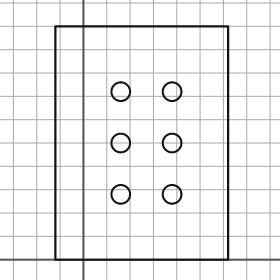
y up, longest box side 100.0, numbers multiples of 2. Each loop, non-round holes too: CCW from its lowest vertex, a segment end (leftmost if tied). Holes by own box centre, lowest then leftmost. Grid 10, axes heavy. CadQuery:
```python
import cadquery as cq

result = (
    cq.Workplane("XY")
    .moveTo(-12.0, 0.0)
    .lineTo(62.0, 0.0)
    .lineTo(62.0, 100.0)
    .lineTo(-12.0, 100.0)
    .close()
    .moveTo(16.0, 28.0)
    .circle(4.0)
    .moveTo(38.0, 28.0)
    .circle(4.0)
    .moveTo(16.0, 50.0)
    .circle(4.0)
    .moveTo(38.0, 50.0)
    .circle(4.0)
    .moveTo(16.0, 72.0)
    .circle(4.0)
    .moveTo(38.0, 72.0)
    .circle(4.0)
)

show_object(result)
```